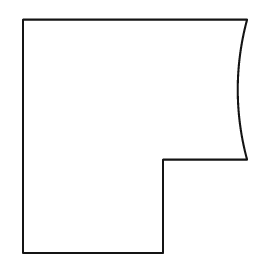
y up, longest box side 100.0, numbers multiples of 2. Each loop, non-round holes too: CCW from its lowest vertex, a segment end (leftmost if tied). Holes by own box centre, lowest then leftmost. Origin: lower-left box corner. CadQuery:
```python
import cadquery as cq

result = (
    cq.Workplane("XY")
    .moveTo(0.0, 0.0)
    .lineTo(60.0, 0.0)
    .lineTo(60.0, 40.0)
    .lineTo(96.0, 40.0)
    .threePointArc((92.0, 70.0), (96.0, 100.0))
    .lineTo(0.0, 100.0)
    .close()
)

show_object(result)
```